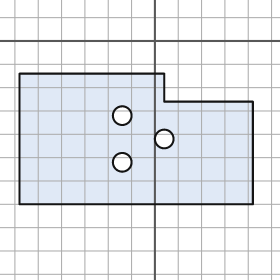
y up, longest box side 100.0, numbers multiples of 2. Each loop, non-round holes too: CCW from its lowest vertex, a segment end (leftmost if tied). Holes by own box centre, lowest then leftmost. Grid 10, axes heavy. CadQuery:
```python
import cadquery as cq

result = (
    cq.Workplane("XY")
    .moveTo(-58.0, -70.0)
    .lineTo(42.0, -70.0)
    .lineTo(42.0, -26.0)
    .lineTo(4.0, -26.0)
    .lineTo(4.0, -14.0)
    .lineTo(-58.0, -14.0)
    .close()
    .moveTo(-14.0, -52.0)
    .circle(4.0)
    .moveTo(4.0, -42.0)
    .circle(4.0)
    .moveTo(-14.0, -32.0)
    .circle(4.0)
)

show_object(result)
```